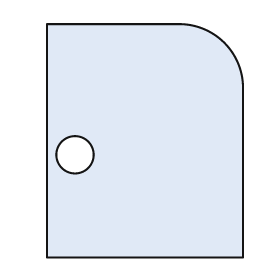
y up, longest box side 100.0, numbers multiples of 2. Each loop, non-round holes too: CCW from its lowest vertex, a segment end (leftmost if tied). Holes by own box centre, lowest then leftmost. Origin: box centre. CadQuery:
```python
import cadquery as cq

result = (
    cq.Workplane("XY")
    .moveTo(-42.0, -50.0)
    .lineTo(42.0, -50.0)
    .lineTo(42.0, 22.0)
    .threePointArc((34.0, 42.0), (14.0, 50.0))
    .lineTo(-42.0, 50.0)
    .close()
    .moveTo(-30.0, -6.0)
    .circle(8.0)
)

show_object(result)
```